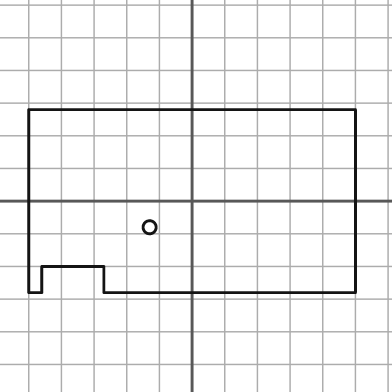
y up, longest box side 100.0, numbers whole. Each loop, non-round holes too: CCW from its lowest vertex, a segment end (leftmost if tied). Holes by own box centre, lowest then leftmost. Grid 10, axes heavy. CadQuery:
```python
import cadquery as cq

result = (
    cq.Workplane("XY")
    .moveTo(-50.0, -28.0)
    .lineTo(-46.0, -28.0)
    .lineTo(-46.0, -20.0)
    .lineTo(-27.0, -20.0)
    .lineTo(-27.0, -28.0)
    .lineTo(50.0, -28.0)
    .lineTo(50.0, 28.0)
    .lineTo(-50.0, 28.0)
    .close()
    .moveTo(-13.0, -8.0)
    .circle(2.0)
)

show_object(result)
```